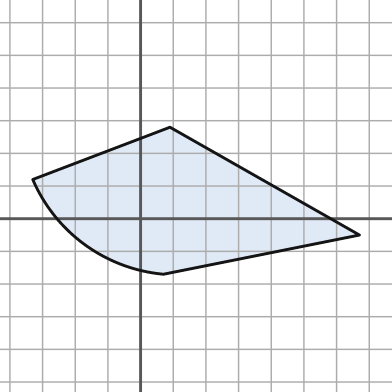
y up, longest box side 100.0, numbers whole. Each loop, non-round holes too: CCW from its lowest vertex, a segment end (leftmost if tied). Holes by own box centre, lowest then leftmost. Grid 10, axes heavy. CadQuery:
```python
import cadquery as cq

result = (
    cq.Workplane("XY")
    .moveTo(7.0, -17.0)
    .lineTo(67.0, -5.0)
    .lineTo(9.0, 28.0)
    .lineTo(-33.0, 12.0)
    .threePointArc((-17.0, -8.0), (7.0, -17.0))
    .close()
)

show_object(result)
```